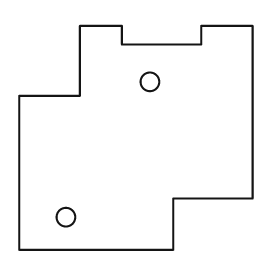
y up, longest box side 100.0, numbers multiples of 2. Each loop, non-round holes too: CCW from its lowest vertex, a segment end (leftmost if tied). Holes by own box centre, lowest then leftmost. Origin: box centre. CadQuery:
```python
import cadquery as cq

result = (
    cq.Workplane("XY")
    .moveTo(-50.0, -48.0)
    .lineTo(16.0, -48.0)
    .lineTo(16.0, -26.0)
    .lineTo(50.0, -26.0)
    .lineTo(50.0, 48.0)
    .lineTo(28.0, 48.0)
    .lineTo(28.0, 40.0)
    .lineTo(-6.0, 40.0)
    .lineTo(-6.0, 48.0)
    .lineTo(-24.0, 48.0)
    .lineTo(-24.0, 18.0)
    .lineTo(-50.0, 18.0)
    .close()
    .moveTo(-30.0, -34.0)
    .circle(4.0)
    .moveTo(6.0, 24.0)
    .circle(4.0)
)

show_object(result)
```